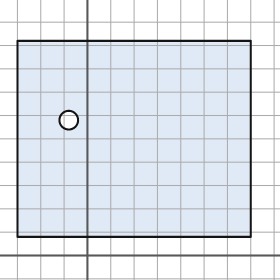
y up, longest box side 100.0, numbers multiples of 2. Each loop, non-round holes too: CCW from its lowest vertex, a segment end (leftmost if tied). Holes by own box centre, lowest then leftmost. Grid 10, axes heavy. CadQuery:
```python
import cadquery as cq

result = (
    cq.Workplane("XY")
    .moveTo(-30.0, 8.0)
    .lineTo(70.0, 8.0)
    .lineTo(70.0, 92.0)
    .lineTo(-30.0, 92.0)
    .close()
    .moveTo(-8.0, 58.0)
    .circle(4.0)
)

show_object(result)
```